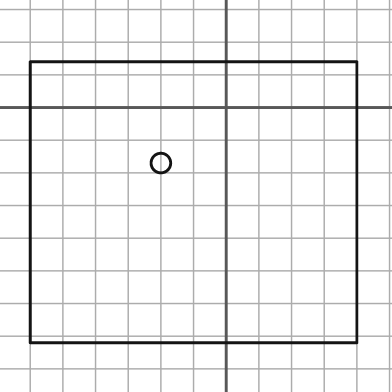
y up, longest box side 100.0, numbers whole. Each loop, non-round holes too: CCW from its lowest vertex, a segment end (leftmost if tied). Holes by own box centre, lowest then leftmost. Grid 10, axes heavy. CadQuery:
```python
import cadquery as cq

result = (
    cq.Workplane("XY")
    .moveTo(-60.0, -72.0)
    .lineTo(40.0, -72.0)
    .lineTo(40.0, 14.0)
    .lineTo(-60.0, 14.0)
    .close()
    .moveTo(-20.0, -17.0)
    .circle(3.0)
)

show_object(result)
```